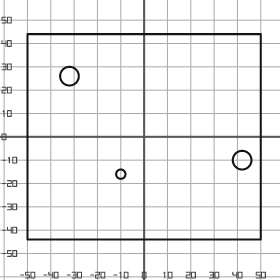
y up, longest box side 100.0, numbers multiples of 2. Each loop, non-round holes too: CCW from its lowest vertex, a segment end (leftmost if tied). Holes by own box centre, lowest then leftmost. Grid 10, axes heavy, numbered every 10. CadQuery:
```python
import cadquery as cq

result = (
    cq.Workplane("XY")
    .moveTo(-50.0, -44.0)
    .lineTo(50.0, -44.0)
    .lineTo(50.0, 44.0)
    .lineTo(-50.0, 44.0)
    .close()
    .moveTo(-10.0, -16.0)
    .circle(2.0)
    .moveTo(42.0, -10.0)
    .circle(4.0)
    .moveTo(-32.0, 26.0)
    .circle(4.0)
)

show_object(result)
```